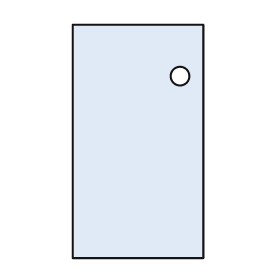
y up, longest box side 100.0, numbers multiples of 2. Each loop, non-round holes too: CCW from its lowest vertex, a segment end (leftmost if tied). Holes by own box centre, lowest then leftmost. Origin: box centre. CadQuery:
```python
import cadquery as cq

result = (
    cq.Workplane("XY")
    .moveTo(-28.0, -50.0)
    .lineTo(28.0, -50.0)
    .lineTo(28.0, 50.0)
    .lineTo(-28.0, 50.0)
    .close()
    .moveTo(18.0, 28.0)
    .circle(4.0)
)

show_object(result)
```